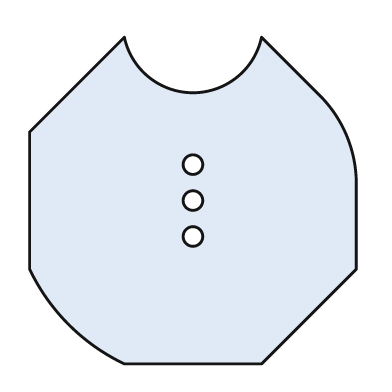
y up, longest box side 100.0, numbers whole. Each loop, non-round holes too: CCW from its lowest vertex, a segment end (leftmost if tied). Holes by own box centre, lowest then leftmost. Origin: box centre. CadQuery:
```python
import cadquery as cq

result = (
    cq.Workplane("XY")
    .moveTo(-21.0, -50.0)
    .lineTo(21.0, -50.0)
    .lineTo(50.0, -21.0)
    .lineTo(50.0, 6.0)
    .threePointArc((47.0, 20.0), (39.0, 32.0))
    .lineTo(21.0, 50.0)
    .threePointArc((0.0, 33.0), (-21.0, 50.0))
    .lineTo(-50.0, 21.0)
    .lineTo(-50.0, -21.0)
    .threePointArc((-38.0, -38.0), (-21.0, -50.0))
    .close()
    .moveTo(0.0, -11.0)
    .circle(3.0)
    .moveTo(0.0, 0.0)
    .circle(3.0)
    .moveTo(0.0, 11.0)
    .circle(3.0)
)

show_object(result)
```